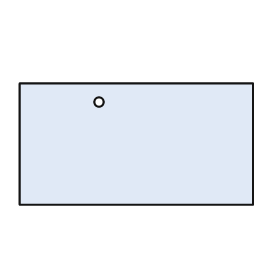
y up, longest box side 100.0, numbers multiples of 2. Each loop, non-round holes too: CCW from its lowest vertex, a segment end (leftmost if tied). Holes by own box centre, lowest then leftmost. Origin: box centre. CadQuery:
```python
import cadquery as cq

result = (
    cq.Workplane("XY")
    .moveTo(-50.0, -26.0)
    .lineTo(50.0, -26.0)
    .lineTo(50.0, 26.0)
    .lineTo(-50.0, 26.0)
    .close()
    .moveTo(-16.0, 18.0)
    .circle(2.0)
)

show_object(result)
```